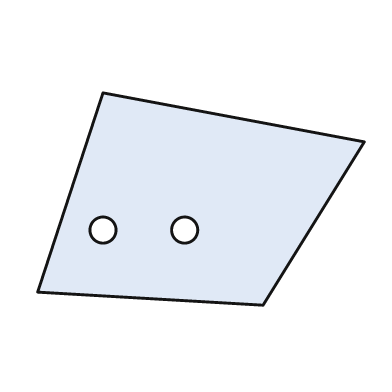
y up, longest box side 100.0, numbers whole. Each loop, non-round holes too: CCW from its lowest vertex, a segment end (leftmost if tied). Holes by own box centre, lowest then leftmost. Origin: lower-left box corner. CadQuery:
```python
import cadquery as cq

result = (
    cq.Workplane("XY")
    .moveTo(69.0, 0.0)
    .lineTo(100.0, 50.0)
    .lineTo(20.0, 65.0)
    .lineTo(0.0, 4.0)
    .close()
    .moveTo(20.0, 23.0)
    .circle(4.0)
    .moveTo(45.0, 23.0)
    .circle(4.0)
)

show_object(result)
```